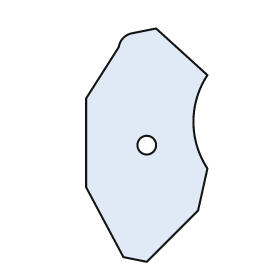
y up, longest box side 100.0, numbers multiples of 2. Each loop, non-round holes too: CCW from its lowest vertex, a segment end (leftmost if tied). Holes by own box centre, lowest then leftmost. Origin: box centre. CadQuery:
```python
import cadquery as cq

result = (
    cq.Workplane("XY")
    .moveTo(0.0, -50.0)
    .lineTo(22.0, -28.0)
    .lineTo(26.0, -10.0)
    .threePointArc((20.0, 10.0), (26.0, 30.0))
    .lineTo(4.0, 50.0)
    .lineTo(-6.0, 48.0)
    .threePointArc((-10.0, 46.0), (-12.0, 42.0))
    .lineTo(-26.0, 20.0)
    .lineTo(-26.0, -18.0)
    .lineTo(-10.0, -48.0)
    .close()
    .moveTo(0.0, 0.0)
    .circle(4.0)
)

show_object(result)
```